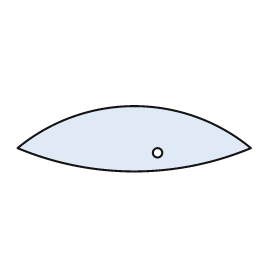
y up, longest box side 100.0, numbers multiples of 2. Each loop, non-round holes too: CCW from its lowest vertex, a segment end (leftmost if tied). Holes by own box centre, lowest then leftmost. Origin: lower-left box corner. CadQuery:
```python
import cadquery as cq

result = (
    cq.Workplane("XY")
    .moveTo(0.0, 10.0)
    .threePointArc((50.0, 0.0), (100.0, 10.0))
    .threePointArc((50.0, 28.0), (0.0, 10.0))
    .close()
    .moveTo(60.0, 8.0)
    .circle(2.0)
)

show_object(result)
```